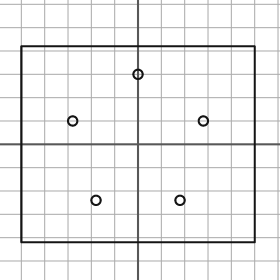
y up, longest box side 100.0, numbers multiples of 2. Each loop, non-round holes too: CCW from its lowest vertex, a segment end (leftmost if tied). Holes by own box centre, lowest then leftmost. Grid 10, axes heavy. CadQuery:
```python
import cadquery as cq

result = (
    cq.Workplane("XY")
    .moveTo(-50.0, -42.0)
    .lineTo(50.0, -42.0)
    .lineTo(50.0, 42.0)
    .lineTo(-50.0, 42.0)
    .close()
    .moveTo(-18.0, -24.0)
    .circle(2.0)
    .moveTo(18.0, -24.0)
    .circle(2.0)
    .moveTo(-28.0, 10.0)
    .circle(2.0)
    .moveTo(28.0, 10.0)
    .circle(2.0)
    .moveTo(0.0, 30.0)
    .circle(2.0)
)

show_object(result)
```